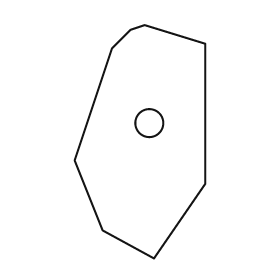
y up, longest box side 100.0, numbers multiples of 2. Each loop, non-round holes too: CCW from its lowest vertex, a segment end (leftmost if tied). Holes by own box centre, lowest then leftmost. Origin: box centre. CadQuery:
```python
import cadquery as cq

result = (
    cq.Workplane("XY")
    .moveTo(6.0, -50.0)
    .lineTo(28.0, -18.0)
    .lineTo(28.0, 42.0)
    .lineTo(2.0, 50.0)
    .lineTo(-4.0, 48.0)
    .lineTo(-12.0, 40.0)
    .lineTo(-28.0, -8.0)
    .lineTo(-16.0, -38.0)
    .close()
    .moveTo(4.0, 8.0)
    .circle(6.0)
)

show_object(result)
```